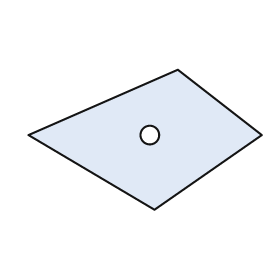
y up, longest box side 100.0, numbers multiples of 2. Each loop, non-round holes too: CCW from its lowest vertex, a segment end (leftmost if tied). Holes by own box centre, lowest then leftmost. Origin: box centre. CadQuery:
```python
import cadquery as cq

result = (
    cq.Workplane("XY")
    .moveTo(4.0, -30.0)
    .lineTo(50.0, 2.0)
    .lineTo(14.0, 30.0)
    .lineTo(-50.0, 2.0)
    .close()
    .moveTo(2.0, 2.0)
    .circle(4.0)
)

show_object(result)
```